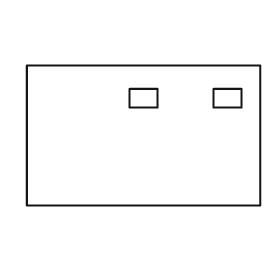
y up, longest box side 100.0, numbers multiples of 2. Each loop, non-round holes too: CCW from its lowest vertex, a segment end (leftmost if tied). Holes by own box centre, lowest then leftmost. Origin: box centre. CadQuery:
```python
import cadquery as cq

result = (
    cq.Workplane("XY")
    .moveTo(-50.0, -30.0)
    .lineTo(50.0, -30.0)
    .lineTo(50.0, 30.0)
    .lineTo(-50.0, 30.0)
    .close()
    .moveTo(-6.0, 12.0)
    .lineTo(6.0, 12.0)
    .lineTo(6.0, 20.0)
    .lineTo(-6.0, 20.0)
    .close()
    .moveTo(30.0, 12.0)
    .lineTo(42.0, 12.0)
    .lineTo(42.0, 20.0)
    .lineTo(30.0, 20.0)
    .close()
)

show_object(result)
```